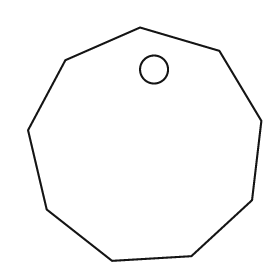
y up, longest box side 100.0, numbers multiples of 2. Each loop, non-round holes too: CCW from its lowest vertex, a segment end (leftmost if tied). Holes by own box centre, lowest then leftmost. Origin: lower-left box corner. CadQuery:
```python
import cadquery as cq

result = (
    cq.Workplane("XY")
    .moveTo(36.0, 0.0)
    .lineTo(70.0, 2.0)
    .lineTo(96.0, 26.0)
    .lineTo(100.0, 60.0)
    .lineTo(82.0, 90.0)
    .lineTo(48.0, 100.0)
    .lineTo(16.0, 86.0)
    .lineTo(0.0, 56.0)
    .lineTo(8.0, 22.0)
    .close()
    .moveTo(54.0, 82.0)
    .circle(6.0)
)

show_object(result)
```